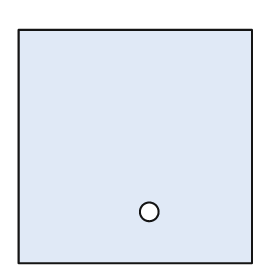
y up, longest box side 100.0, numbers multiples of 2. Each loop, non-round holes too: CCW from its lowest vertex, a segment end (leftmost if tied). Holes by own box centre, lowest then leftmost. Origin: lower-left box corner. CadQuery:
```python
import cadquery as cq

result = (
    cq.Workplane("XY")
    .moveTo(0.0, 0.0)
    .lineTo(100.0, 0.0)
    .lineTo(100.0, 100.0)
    .lineTo(0.0, 100.0)
    .close()
    .moveTo(56.0, 22.0)
    .circle(4.0)
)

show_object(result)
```